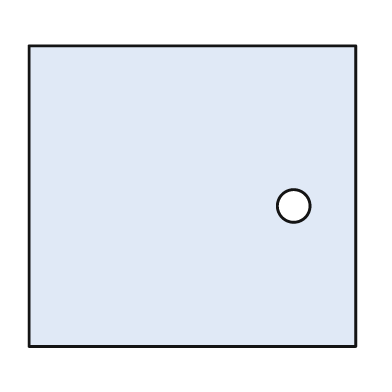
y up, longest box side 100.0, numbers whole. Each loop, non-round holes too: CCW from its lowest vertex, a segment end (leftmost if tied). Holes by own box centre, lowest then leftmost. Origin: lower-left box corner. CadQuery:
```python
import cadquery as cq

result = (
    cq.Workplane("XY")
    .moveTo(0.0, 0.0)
    .lineTo(100.0, 0.0)
    .lineTo(100.0, 92.0)
    .lineTo(0.0, 92.0)
    .close()
    .moveTo(81.0, 43.0)
    .circle(5.0)
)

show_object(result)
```